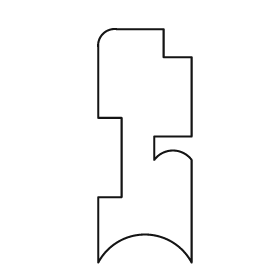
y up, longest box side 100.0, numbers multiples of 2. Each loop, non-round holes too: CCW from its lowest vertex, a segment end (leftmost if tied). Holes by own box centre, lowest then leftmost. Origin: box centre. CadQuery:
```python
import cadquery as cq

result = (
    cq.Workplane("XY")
    .moveTo(-20.0, -50.0)
    .threePointArc((0.0, -38.0), (20.0, -50.0))
    .lineTo(20.0, -6.0)
    .threePointArc((12.0, -2.0), (4.0, -6.0))
    .lineTo(4.0, 4.0)
    .lineTo(20.0, 4.0)
    .lineTo(20.0, 38.0)
    .lineTo(8.0, 38.0)
    .lineTo(8.0, 50.0)
    .lineTo(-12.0, 50.0)
    .threePointArc((-18.0, 48.0), (-20.0, 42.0))
    .lineTo(-20.0, 12.0)
    .lineTo(-10.0, 12.0)
    .lineTo(-10.0, -22.0)
    .lineTo(-20.0, -22.0)
    .close()
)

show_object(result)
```